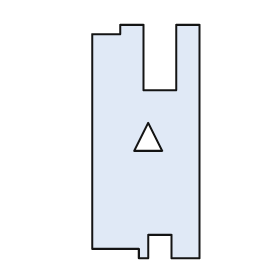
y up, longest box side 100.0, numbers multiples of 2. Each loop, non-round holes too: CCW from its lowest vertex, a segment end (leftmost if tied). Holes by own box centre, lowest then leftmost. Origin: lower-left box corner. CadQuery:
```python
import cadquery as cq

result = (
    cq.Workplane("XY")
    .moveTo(20.0, 0.0)
    .lineTo(24.0, 0.0)
    .lineTo(24.0, 10.0)
    .lineTo(34.0, 10.0)
    .lineTo(34.0, 0.0)
    .lineTo(46.0, 0.0)
    .lineTo(46.0, 100.0)
    .lineTo(36.0, 100.0)
    .lineTo(36.0, 72.0)
    .lineTo(22.0, 72.0)
    .lineTo(22.0, 100.0)
    .lineTo(12.0, 100.0)
    .lineTo(12.0, 96.0)
    .lineTo(0.0, 96.0)
    .lineTo(0.0, 4.0)
    .lineTo(20.0, 4.0)
    .close()
    .moveTo(18.0, 46.0)
    .lineTo(30.0, 46.0)
    .lineTo(24.0, 58.0)
    .close()
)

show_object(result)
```